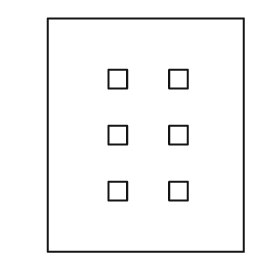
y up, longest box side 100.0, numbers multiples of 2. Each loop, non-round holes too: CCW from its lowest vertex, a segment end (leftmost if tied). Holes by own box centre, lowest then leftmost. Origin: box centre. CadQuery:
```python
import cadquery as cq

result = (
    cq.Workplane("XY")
    .moveTo(-42.0, -50.0)
    .lineTo(42.0, -50.0)
    .lineTo(42.0, 50.0)
    .lineTo(-42.0, 50.0)
    .close()
    .moveTo(-16.0, -28.0)
    .lineTo(-8.0, -28.0)
    .lineTo(-8.0, -20.0)
    .lineTo(-16.0, -20.0)
    .close()
    .moveTo(10.0, -28.0)
    .lineTo(18.0, -28.0)
    .lineTo(18.0, -20.0)
    .lineTo(10.0, -20.0)
    .close()
    .moveTo(-16.0, -4.0)
    .lineTo(-8.0, -4.0)
    .lineTo(-8.0, 4.0)
    .lineTo(-16.0, 4.0)
    .close()
    .moveTo(10.0, -4.0)
    .lineTo(18.0, -4.0)
    .lineTo(18.0, 4.0)
    .lineTo(10.0, 4.0)
    .close()
    .moveTo(-16.0, 20.0)
    .lineTo(-8.0, 20.0)
    .lineTo(-8.0, 28.0)
    .lineTo(-16.0, 28.0)
    .close()
    .moveTo(10.0, 20.0)
    .lineTo(18.0, 20.0)
    .lineTo(18.0, 28.0)
    .lineTo(10.0, 28.0)
    .close()
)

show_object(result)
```